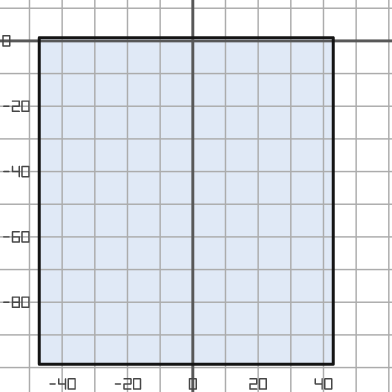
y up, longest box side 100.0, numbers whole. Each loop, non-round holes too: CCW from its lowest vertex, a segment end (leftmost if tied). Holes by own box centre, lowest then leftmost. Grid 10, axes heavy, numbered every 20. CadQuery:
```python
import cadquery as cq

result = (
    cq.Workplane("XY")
    .moveTo(-47.0, -99.0)
    .lineTo(43.0, -99.0)
    .lineTo(43.0, 1.0)
    .lineTo(-47.0, 1.0)
    .close()
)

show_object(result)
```